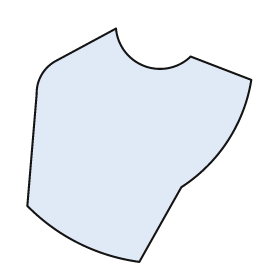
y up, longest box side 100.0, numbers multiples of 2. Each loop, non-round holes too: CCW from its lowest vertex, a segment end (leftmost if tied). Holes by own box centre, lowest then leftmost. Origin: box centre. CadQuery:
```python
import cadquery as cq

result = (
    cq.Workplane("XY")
    .moveTo(0.0, -50.0)
    .lineTo(18.0, -18.0)
    .threePointArc((38.0, 2.0), (48.0, 28.0))
    .lineTo(22.0, 38.0)
    .threePointArc((2.0, 34.0), (-10.0, 50.0))
    .lineTo(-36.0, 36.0)
    .threePointArc((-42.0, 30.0), (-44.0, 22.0))
    .lineTo(-48.0, -26.0)
    .threePointArc((-26.0, -42.0), (0.0, -50.0))
    .close()
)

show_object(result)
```